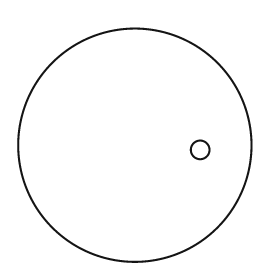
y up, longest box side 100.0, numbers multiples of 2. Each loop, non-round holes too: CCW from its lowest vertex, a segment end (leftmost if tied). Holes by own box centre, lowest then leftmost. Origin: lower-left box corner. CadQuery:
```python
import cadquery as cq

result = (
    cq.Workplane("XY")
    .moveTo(50.0, 50.0)
    .circle(50.0)
    .moveTo(78.0, 48.0)
    .circle(4.0)
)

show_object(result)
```